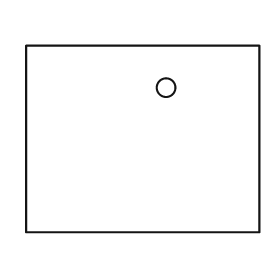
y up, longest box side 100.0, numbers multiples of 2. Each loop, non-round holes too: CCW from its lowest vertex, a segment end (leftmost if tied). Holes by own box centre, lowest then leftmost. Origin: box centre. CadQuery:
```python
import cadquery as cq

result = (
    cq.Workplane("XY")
    .moveTo(-50.0, -40.0)
    .lineTo(50.0, -40.0)
    .lineTo(50.0, 40.0)
    .lineTo(-50.0, 40.0)
    .close()
    .moveTo(10.0, 22.0)
    .circle(4.0)
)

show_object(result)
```